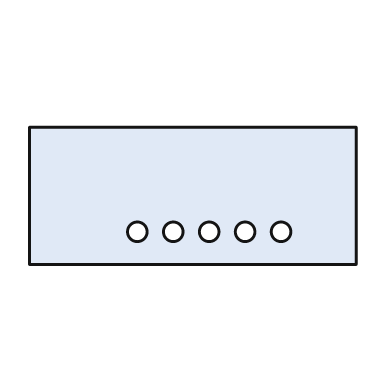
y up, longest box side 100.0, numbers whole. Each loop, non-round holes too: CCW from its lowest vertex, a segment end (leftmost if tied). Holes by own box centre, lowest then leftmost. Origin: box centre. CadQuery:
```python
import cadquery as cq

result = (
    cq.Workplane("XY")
    .moveTo(-50.0, -21.0)
    .lineTo(50.0, -21.0)
    .lineTo(50.0, 21.0)
    .lineTo(-50.0, 21.0)
    .close()
    .moveTo(-17.0, -11.0)
    .circle(3.0)
    .moveTo(-6.0, -11.0)
    .circle(3.0)
    .moveTo(5.0, -11.0)
    .circle(3.0)
    .moveTo(16.0, -11.0)
    .circle(3.0)
    .moveTo(27.0, -11.0)
    .circle(3.0)
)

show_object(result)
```